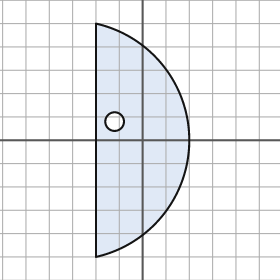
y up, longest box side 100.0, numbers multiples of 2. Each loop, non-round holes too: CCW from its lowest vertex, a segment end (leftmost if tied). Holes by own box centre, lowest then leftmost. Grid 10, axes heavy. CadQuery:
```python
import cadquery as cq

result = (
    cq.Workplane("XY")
    .moveTo(-20.0, -50.0)
    .threePointArc((20.0, 0.0), (-20.0, 50.0))
    .close()
    .moveTo(-12.0, 8.0)
    .circle(4.0)
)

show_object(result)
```